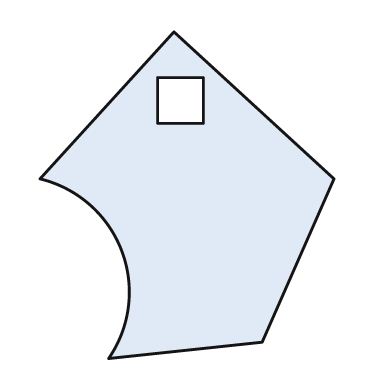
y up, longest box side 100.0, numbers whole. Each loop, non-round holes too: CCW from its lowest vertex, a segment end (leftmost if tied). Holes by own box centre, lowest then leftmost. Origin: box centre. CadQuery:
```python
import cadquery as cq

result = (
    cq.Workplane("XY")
    .moveTo(-24.0, -50.0)
    .lineTo(23.0, -45.0)
    .lineTo(45.0, 5.0)
    .lineTo(-4.0, 50.0)
    .lineTo(-45.0, 5.0)
    .threePointArc((-20.0, -17.0), (-24.0, -50.0))
    .close()
    .moveTo(-9.0, 22.0)
    .lineTo(5.0, 22.0)
    .lineTo(5.0, 36.0)
    .lineTo(-9.0, 36.0)
    .close()
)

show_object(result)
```